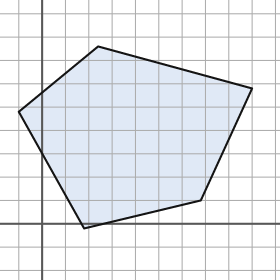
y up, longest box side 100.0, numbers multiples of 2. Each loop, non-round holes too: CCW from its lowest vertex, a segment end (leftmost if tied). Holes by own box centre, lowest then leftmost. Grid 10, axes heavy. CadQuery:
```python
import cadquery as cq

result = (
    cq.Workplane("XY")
    .moveTo(18.0, -2.0)
    .lineTo(68.0, 10.0)
    .lineTo(90.0, 58.0)
    .lineTo(24.0, 76.0)
    .lineTo(-10.0, 48.0)
    .close()
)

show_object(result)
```